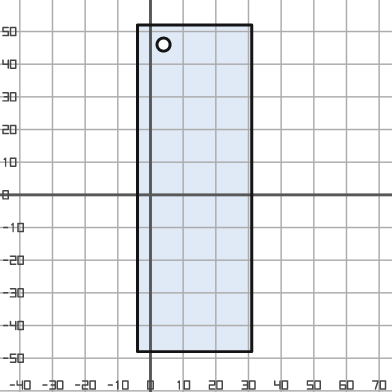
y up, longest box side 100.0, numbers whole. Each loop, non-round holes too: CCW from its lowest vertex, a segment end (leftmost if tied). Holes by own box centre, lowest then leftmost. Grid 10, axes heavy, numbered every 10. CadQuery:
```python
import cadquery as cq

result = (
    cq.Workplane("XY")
    .moveTo(-4.0, -48.0)
    .lineTo(31.0, -48.0)
    .lineTo(31.0, 52.0)
    .lineTo(-4.0, 52.0)
    .close()
    .moveTo(4.0, 46.0)
    .circle(2.0)
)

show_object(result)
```